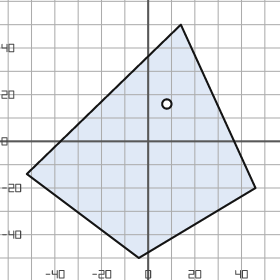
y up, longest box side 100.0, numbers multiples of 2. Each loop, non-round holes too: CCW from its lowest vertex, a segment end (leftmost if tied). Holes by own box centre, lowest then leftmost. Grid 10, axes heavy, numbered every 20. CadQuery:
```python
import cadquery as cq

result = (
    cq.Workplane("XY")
    .moveTo(-4.0, -50.0)
    .lineTo(46.0, -20.0)
    .lineTo(14.0, 50.0)
    .lineTo(-52.0, -14.0)
    .close()
    .moveTo(8.0, 16.0)
    .circle(2.0)
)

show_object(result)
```